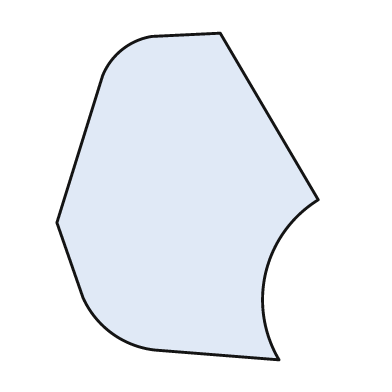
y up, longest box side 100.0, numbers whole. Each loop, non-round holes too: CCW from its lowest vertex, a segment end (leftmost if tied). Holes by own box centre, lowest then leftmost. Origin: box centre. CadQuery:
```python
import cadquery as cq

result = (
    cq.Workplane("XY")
    .moveTo(28.0, -50.0)
    .threePointArc((24.0, -23.0), (40.0, -1.0))
    .lineTo(10.0, 50.0)
    .lineTo(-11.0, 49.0)
    .threePointArc((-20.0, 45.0), (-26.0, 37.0))
    .lineTo(-40.0, -8.0)
    .lineTo(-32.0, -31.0)
    .threePointArc((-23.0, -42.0), (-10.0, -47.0))
    .close()
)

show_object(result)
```